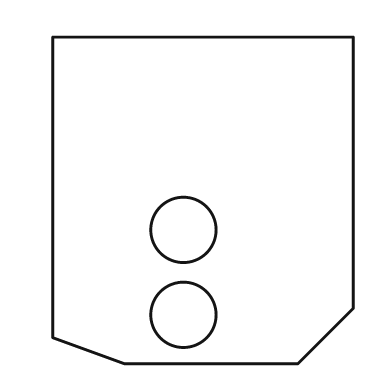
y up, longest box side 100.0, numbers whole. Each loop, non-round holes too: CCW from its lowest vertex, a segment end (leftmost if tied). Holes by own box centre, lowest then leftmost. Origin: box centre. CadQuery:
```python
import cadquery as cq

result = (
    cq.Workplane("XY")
    .moveTo(-24.0, -50.0)
    .lineTo(29.0, -50.0)
    .lineTo(46.0, -33.0)
    .lineTo(46.0, 50.0)
    .lineTo(-46.0, 50.0)
    .lineTo(-46.0, -42.0)
    .close()
    .moveTo(-6.0, -35.0)
    .circle(10.0)
    .moveTo(-6.0, -9.0)
    .circle(10.0)
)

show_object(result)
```